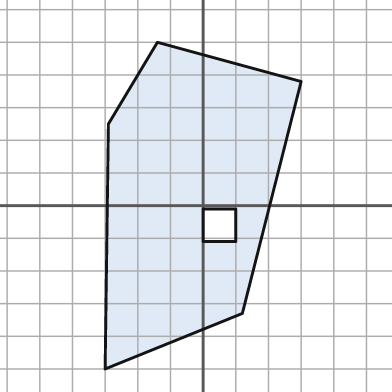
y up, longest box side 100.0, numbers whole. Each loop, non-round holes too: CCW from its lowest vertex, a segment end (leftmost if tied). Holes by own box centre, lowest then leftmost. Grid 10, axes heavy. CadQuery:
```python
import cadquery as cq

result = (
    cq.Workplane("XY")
    .moveTo(-30.0, -50.0)
    .lineTo(12.0, -33.0)
    .lineTo(30.0, 38.0)
    .lineTo(-14.0, 50.0)
    .lineTo(-29.0, 25.0)
    .close()
    .moveTo(0.0, -11.0)
    .lineTo(10.0, -11.0)
    .lineTo(10.0, -1.0)
    .lineTo(0.0, -1.0)
    .close()
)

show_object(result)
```